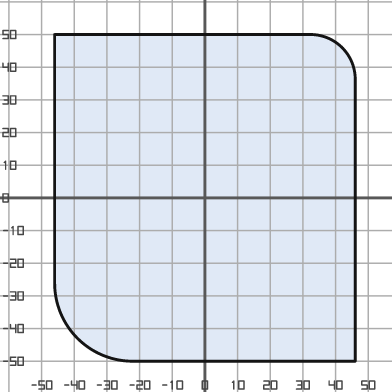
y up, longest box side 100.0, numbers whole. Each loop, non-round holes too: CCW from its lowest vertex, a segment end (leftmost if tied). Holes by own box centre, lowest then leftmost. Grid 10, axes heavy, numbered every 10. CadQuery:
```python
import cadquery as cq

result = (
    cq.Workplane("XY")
    .moveTo(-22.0, -50.0)
    .lineTo(46.0, -50.0)
    .lineTo(46.0, 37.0)
    .threePointArc((42.0, 46.0), (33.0, 50.0))
    .lineTo(-46.0, 50.0)
    .lineTo(-46.0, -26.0)
    .threePointArc((-39.0, -43.0), (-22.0, -50.0))
    .close()
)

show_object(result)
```